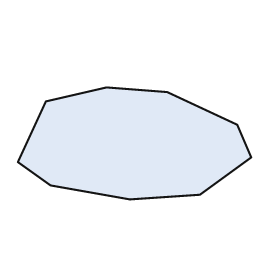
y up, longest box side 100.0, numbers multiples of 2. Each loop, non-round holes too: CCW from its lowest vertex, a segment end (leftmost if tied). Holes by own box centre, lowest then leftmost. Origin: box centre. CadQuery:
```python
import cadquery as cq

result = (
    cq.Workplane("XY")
    .moveTo(-2.0, -24.0)
    .lineTo(28.0, -22.0)
    .lineTo(50.0, -6.0)
    .lineTo(44.0, 8.0)
    .lineTo(14.0, 22.0)
    .lineTo(-12.0, 24.0)
    .lineTo(-38.0, 18.0)
    .lineTo(-50.0, -8.0)
    .lineTo(-36.0, -18.0)
    .close()
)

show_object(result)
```